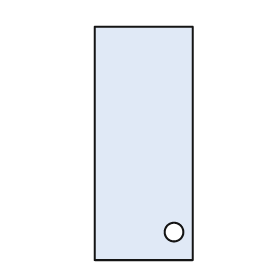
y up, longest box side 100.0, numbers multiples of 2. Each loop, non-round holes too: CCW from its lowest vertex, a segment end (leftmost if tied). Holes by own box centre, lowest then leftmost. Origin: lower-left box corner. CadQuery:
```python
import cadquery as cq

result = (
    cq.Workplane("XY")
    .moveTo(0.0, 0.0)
    .lineTo(42.0, 0.0)
    .lineTo(42.0, 100.0)
    .lineTo(0.0, 100.0)
    .close()
    .moveTo(34.0, 12.0)
    .circle(4.0)
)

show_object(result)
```